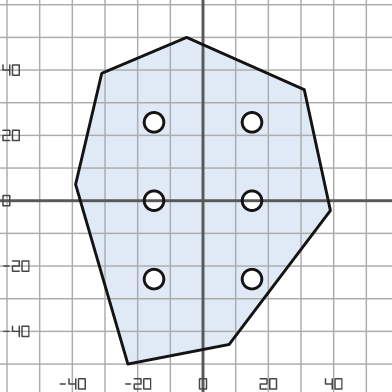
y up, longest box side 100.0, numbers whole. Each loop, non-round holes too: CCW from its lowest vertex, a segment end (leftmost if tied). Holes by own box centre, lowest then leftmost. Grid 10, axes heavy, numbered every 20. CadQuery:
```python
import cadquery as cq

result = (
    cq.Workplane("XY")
    .moveTo(-23.0, -50.0)
    .lineTo(8.0, -44.0)
    .lineTo(39.0, -3.0)
    .lineTo(31.0, 34.0)
    .lineTo(-5.0, 50.0)
    .lineTo(-31.0, 39.0)
    .lineTo(-39.0, 5.0)
    .close()
    .moveTo(-15.0, -24.0)
    .circle(3.0)
    .moveTo(15.0, -24.0)
    .circle(3.0)
    .moveTo(-15.0, 0.0)
    .circle(3.0)
    .moveTo(15.0, 0.0)
    .circle(3.0)
    .moveTo(-15.0, 24.0)
    .circle(3.0)
    .moveTo(15.0, 24.0)
    .circle(3.0)
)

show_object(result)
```